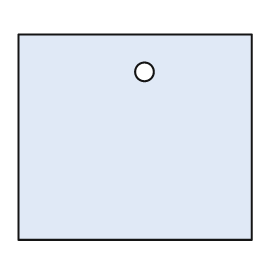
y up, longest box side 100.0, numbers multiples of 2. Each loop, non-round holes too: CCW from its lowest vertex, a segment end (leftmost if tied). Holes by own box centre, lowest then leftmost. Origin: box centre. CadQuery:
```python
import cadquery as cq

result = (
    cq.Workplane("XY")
    .moveTo(-50.0, -44.0)
    .lineTo(50.0, -44.0)
    .lineTo(50.0, 44.0)
    .lineTo(-50.0, 44.0)
    .close()
    .moveTo(4.0, 28.0)
    .circle(4.0)
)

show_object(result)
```